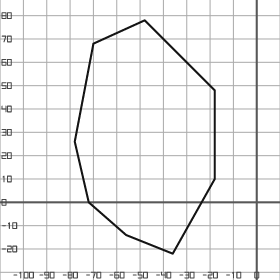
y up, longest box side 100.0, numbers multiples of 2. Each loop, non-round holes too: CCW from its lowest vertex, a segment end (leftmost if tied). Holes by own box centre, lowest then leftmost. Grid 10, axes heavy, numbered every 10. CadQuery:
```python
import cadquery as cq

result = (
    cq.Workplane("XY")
    .moveTo(-36.0, -22.0)
    .lineTo(-18.0, 10.0)
    .lineTo(-18.0, 48.0)
    .lineTo(-48.0, 78.0)
    .lineTo(-70.0, 68.0)
    .lineTo(-78.0, 26.0)
    .lineTo(-72.0, 0.0)
    .lineTo(-56.0, -14.0)
    .close()
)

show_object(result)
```